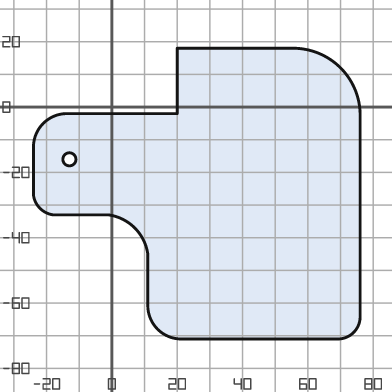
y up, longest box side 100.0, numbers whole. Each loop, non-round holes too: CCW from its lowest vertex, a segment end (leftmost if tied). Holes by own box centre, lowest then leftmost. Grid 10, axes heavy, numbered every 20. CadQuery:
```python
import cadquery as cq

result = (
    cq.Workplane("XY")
    .moveTo(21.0, -71.0)
    .lineTo(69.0, -71.0)
    .threePointArc((74.0, -69.0), (76.0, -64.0))
    .lineTo(76.0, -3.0)
    .threePointArc((70.0, 12.0), (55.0, 18.0))
    .lineTo(20.0, 18.0)
    .lineTo(20.0, -2.0)
    .lineTo(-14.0, -2.0)
    .threePointArc((-21.0, -5.0), (-24.0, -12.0))
    .lineTo(-24.0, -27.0)
    .threePointArc((-22.0, -31.0), (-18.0, -33.0))
    .lineTo(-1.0, -33.0)
    .threePointArc((7.0, -37.0), (11.0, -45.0))
    .lineTo(11.0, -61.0)
    .threePointArc((14.0, -68.0), (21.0, -71.0))
    .close()
    .moveTo(-13.0, -16.0)
    .circle(2.0)
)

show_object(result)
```